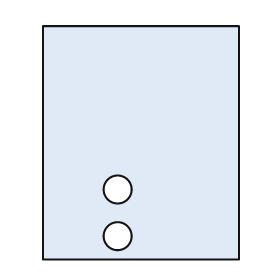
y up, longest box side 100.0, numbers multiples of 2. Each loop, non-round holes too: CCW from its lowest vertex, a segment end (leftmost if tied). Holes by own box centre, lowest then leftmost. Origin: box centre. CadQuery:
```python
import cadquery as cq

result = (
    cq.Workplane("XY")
    .moveTo(-42.0, -50.0)
    .lineTo(42.0, -50.0)
    .lineTo(42.0, 50.0)
    .lineTo(-42.0, 50.0)
    .close()
    .moveTo(-10.0, -40.0)
    .circle(6.0)
    .moveTo(-10.0, -20.0)
    .circle(6.0)
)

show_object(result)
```